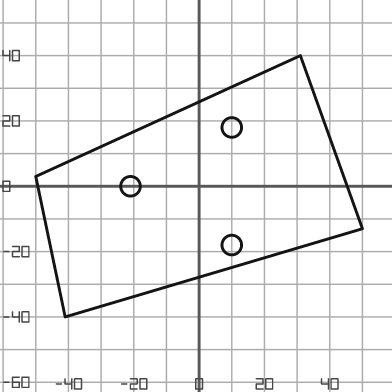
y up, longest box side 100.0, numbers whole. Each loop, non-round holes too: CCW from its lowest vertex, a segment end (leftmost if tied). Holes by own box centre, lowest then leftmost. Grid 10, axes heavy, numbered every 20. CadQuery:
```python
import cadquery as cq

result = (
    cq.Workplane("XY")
    .moveTo(-41.0, -40.0)
    .lineTo(50.0, -13.0)
    .lineTo(31.0, 40.0)
    .lineTo(-50.0, 3.0)
    .close()
    .moveTo(10.0, -18.0)
    .circle(3.0)
    .moveTo(-21.0, 0.0)
    .circle(3.0)
    .moveTo(10.0, 18.0)
    .circle(3.0)
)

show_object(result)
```